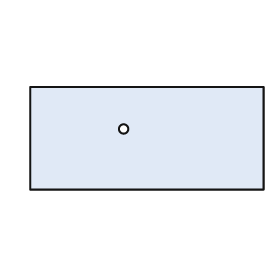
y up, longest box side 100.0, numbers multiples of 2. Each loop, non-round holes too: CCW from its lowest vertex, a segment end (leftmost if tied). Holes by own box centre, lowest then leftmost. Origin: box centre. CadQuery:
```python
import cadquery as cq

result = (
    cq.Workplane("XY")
    .moveTo(-50.0, -22.0)
    .lineTo(50.0, -22.0)
    .lineTo(50.0, 22.0)
    .lineTo(-50.0, 22.0)
    .close()
    .moveTo(-10.0, 4.0)
    .circle(2.0)
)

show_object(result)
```